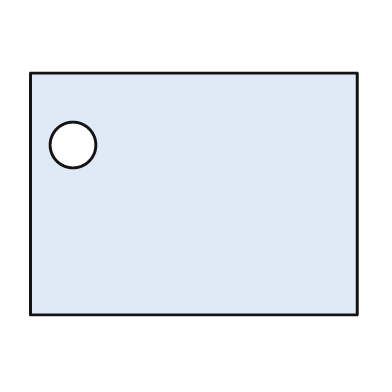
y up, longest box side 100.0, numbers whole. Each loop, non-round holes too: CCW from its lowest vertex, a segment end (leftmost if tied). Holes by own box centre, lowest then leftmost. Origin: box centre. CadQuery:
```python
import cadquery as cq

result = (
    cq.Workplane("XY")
    .moveTo(-50.0, -37.0)
    .lineTo(50.0, -37.0)
    .lineTo(50.0, 37.0)
    .lineTo(-50.0, 37.0)
    .close()
    .moveTo(-37.0, 15.0)
    .circle(7.0)
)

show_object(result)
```